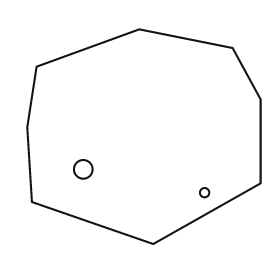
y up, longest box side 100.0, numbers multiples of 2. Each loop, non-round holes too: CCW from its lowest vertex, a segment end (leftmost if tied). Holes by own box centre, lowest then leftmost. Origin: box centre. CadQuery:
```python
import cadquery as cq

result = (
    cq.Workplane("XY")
    .moveTo(4.0, -46.0)
    .lineTo(50.0, -20.0)
    .lineTo(50.0, 16.0)
    .lineTo(38.0, 38.0)
    .lineTo(-2.0, 46.0)
    .lineTo(-46.0, 30.0)
    .lineTo(-50.0, 4.0)
    .lineTo(-48.0, -28.0)
    .close()
    .moveTo(26.0, -24.0)
    .circle(2.0)
    .moveTo(-26.0, -14.0)
    .circle(4.0)
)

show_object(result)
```